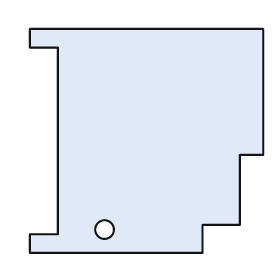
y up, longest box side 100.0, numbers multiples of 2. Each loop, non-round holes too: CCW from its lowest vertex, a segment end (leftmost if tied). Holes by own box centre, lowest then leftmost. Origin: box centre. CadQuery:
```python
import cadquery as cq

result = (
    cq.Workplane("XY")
    .moveTo(-50.0, -48.0)
    .lineTo(24.0, -48.0)
    .lineTo(24.0, -36.0)
    .lineTo(40.0, -36.0)
    .lineTo(40.0, -6.0)
    .lineTo(50.0, -6.0)
    .lineTo(50.0, 48.0)
    .lineTo(-50.0, 48.0)
    .lineTo(-50.0, 40.0)
    .lineTo(-38.0, 40.0)
    .lineTo(-38.0, -40.0)
    .lineTo(-50.0, -40.0)
    .close()
    .moveTo(-18.0, -38.0)
    .circle(4.0)
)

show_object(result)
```